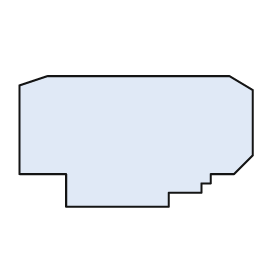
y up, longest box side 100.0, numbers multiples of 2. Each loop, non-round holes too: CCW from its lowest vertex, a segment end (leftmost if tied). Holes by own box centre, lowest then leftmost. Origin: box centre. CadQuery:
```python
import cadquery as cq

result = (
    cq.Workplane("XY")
    .moveTo(-30.0, -28.0)
    .lineTo(14.0, -28.0)
    .lineTo(14.0, -22.0)
    .lineTo(28.0, -22.0)
    .lineTo(28.0, -18.0)
    .lineTo(32.0, -18.0)
    .lineTo(32.0, -14.0)
    .lineTo(42.0, -14.0)
    .lineTo(50.0, -6.0)
    .lineTo(50.0, 22.0)
    .lineTo(40.0, 28.0)
    .lineTo(-38.0, 28.0)
    .lineTo(-50.0, 24.0)
    .lineTo(-50.0, -14.0)
    .lineTo(-30.0, -14.0)
    .close()
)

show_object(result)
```